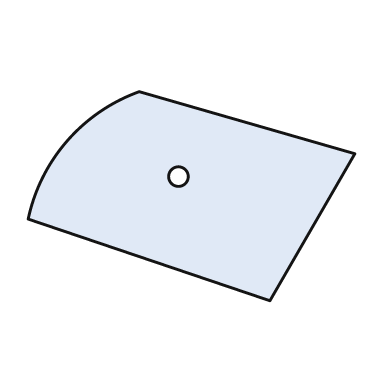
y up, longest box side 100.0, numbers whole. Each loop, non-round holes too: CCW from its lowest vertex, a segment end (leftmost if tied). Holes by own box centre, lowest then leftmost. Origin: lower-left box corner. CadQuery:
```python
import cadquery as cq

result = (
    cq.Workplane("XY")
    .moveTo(74.0, 0.0)
    .lineTo(100.0, 45.0)
    .lineTo(34.0, 64.0)
    .threePointArc((12.0, 49.0), (0.0, 25.0))
    .close()
    .moveTo(46.0, 38.0)
    .circle(3.0)
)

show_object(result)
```